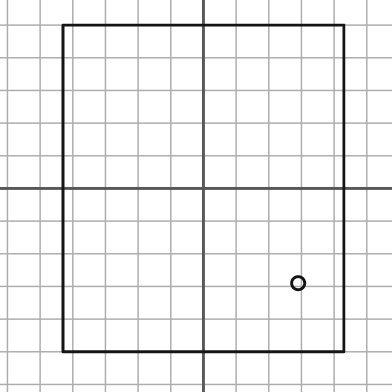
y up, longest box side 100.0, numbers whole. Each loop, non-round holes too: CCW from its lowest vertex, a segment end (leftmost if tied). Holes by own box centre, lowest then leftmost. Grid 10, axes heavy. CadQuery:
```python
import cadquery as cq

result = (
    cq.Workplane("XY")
    .moveTo(-43.0, -50.0)
    .lineTo(43.0, -50.0)
    .lineTo(43.0, 50.0)
    .lineTo(-43.0, 50.0)
    .close()
    .moveTo(29.0, -29.0)
    .circle(2.0)
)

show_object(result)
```